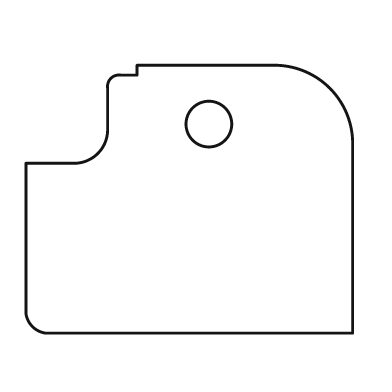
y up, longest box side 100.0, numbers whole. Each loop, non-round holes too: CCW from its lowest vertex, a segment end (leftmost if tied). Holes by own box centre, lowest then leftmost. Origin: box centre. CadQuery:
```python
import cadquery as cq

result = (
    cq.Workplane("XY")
    .moveTo(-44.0, -41.0)
    .lineTo(50.0, -41.0)
    .lineTo(50.0, 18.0)
    .threePointArc((43.0, 34.0), (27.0, 41.0))
    .lineTo(-16.0, 41.0)
    .lineTo(-16.0, 38.0)
    .lineTo(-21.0, 38.0)
    .threePointArc((-24.0, 37.0), (-25.0, 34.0))
    .lineTo(-25.0, 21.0)
    .threePointArc((-28.0, 14.0), (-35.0, 11.0))
    .lineTo(-50.0, 11.0)
    .lineTo(-50.0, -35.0)
    .threePointArc((-48.0, -39.0), (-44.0, -41.0))
    .close()
    .moveTo(6.0, 23.0)
    .circle(7.0)
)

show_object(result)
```